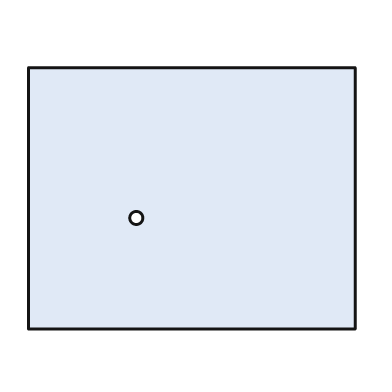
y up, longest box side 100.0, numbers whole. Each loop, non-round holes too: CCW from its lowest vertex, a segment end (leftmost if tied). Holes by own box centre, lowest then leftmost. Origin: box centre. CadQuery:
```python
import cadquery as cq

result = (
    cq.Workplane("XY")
    .moveTo(-50.0, -40.0)
    .lineTo(50.0, -40.0)
    .lineTo(50.0, 40.0)
    .lineTo(-50.0, 40.0)
    .close()
    .moveTo(-17.0, -6.0)
    .circle(2.0)
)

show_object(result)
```